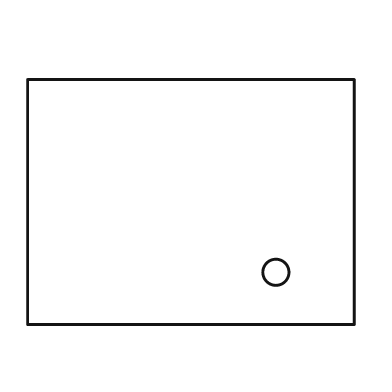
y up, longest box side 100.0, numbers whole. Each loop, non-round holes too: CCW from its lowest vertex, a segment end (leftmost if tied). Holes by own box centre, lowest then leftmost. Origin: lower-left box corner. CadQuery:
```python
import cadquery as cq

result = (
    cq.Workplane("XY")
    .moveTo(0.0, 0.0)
    .lineTo(100.0, 0.0)
    .lineTo(100.0, 75.0)
    .lineTo(0.0, 75.0)
    .close()
    .moveTo(76.0, 16.0)
    .circle(4.0)
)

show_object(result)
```